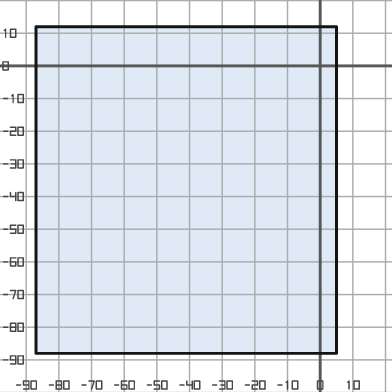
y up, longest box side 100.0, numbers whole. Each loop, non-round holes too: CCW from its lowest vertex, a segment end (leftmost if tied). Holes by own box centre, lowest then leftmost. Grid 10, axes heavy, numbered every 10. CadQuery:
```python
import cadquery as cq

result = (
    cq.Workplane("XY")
    .moveTo(-87.0, -88.0)
    .lineTo(5.0, -88.0)
    .lineTo(5.0, 12.0)
    .lineTo(-87.0, 12.0)
    .close()
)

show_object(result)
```